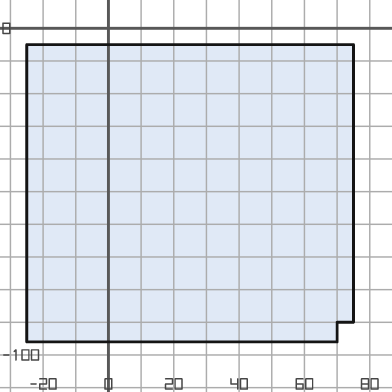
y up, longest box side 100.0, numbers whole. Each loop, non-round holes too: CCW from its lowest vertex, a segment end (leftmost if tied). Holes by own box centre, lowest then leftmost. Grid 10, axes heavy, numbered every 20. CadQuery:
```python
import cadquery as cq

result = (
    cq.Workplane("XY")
    .moveTo(-25.0, -96.0)
    .lineTo(70.0, -96.0)
    .lineTo(70.0, -90.0)
    .lineTo(75.0, -90.0)
    .lineTo(75.0, -5.0)
    .lineTo(-25.0, -5.0)
    .close()
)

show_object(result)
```